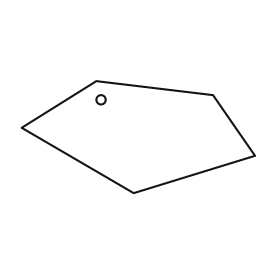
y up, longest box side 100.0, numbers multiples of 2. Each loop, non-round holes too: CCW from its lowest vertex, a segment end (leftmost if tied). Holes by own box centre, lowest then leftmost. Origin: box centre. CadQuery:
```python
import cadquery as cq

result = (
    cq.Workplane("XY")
    .moveTo(-2.0, -24.0)
    .lineTo(50.0, -8.0)
    .lineTo(32.0, 18.0)
    .lineTo(-18.0, 24.0)
    .lineTo(-50.0, 4.0)
    .close()
    .moveTo(-16.0, 16.0)
    .circle(2.0)
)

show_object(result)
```